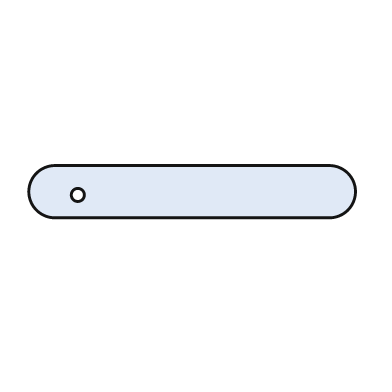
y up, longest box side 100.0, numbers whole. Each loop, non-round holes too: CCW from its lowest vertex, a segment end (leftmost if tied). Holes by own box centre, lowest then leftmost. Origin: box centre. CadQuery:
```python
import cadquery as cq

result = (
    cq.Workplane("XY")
    .moveTo(-42.0, -8.0)
    .lineTo(42.0, -8.0)
    .threePointArc((50.0, 0.0), (42.0, 8.0))
    .lineTo(-42.0, 8.0)
    .threePointArc((-50.0, 0.0), (-42.0, -8.0))
    .close()
    .moveTo(-35.0, -1.0)
    .circle(2.0)
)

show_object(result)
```